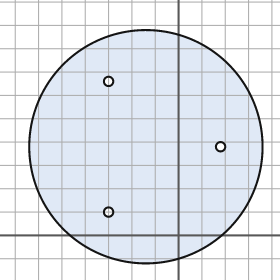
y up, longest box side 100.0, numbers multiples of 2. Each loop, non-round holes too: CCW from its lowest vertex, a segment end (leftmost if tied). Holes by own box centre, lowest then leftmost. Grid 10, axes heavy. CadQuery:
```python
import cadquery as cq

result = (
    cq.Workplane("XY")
    .moveTo(-14.0, 38.0)
    .circle(50.0)
    .moveTo(-30.0, 10.0)
    .circle(2.0)
    .moveTo(18.0, 38.0)
    .circle(2.0)
    .moveTo(-30.0, 66.0)
    .circle(2.0)
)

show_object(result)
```